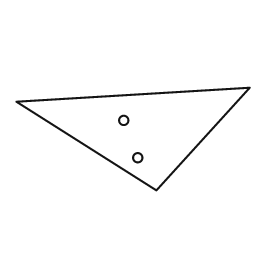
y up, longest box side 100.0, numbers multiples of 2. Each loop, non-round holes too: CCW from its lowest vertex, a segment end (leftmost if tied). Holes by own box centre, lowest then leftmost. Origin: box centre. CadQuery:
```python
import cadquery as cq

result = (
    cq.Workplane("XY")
    .moveTo(10.0, -22.0)
    .lineTo(50.0, 22.0)
    .lineTo(-50.0, 16.0)
    .close()
    .moveTo(2.0, -8.0)
    .circle(2.0)
    .moveTo(-4.0, 8.0)
    .circle(2.0)
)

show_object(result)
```